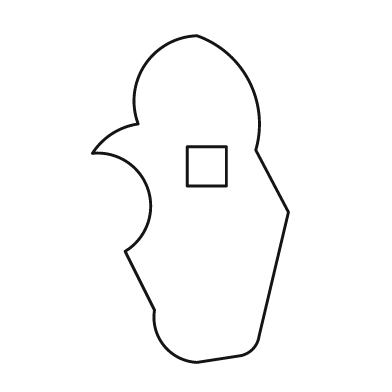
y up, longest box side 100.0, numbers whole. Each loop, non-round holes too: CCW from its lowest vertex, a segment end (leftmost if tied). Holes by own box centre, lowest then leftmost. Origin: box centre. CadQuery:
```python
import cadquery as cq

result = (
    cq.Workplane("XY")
    .moveTo(2.0, -50.0)
    .lineTo(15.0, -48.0)
    .threePointArc((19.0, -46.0), (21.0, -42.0))
    .lineTo(30.0, -4.0)
    .lineTo(20.0, 15.0)
    .threePointArc((18.0, 36.0), (2.0, 50.0))
    .threePointArc((-14.0, 41.0), (-16.0, 23.0))
    .threePointArc((-24.0, 20.0), (-30.0, 14.0))
    .threePointArc((-13.0, 3.0), (-20.0, -16.0))
    .lineTo(-11.0, -34.0)
    .threePointArc((-8.0, -45.0), (2.0, -50.0))
    .close()
    .moveTo(-1.0, 4.0)
    .lineTo(11.0, 4.0)
    .lineTo(11.0, 16.0)
    .lineTo(-1.0, 16.0)
    .close()
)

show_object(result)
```